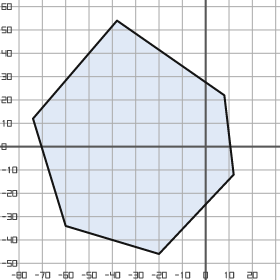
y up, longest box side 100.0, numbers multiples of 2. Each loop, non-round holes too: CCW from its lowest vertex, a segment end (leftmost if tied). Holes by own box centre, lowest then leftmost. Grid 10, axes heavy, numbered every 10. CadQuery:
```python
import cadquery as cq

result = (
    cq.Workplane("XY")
    .moveTo(-20.0, -46.0)
    .lineTo(12.0, -12.0)
    .lineTo(8.0, 22.0)
    .lineTo(-38.0, 54.0)
    .lineTo(-74.0, 12.0)
    .lineTo(-60.0, -34.0)
    .close()
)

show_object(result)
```